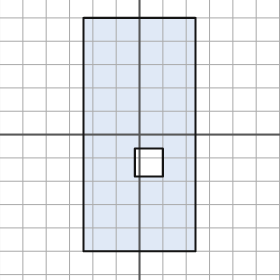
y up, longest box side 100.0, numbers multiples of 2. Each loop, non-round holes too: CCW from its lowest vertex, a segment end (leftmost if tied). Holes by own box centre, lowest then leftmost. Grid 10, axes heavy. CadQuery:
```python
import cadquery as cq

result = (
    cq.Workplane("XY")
    .moveTo(-24.0, -50.0)
    .lineTo(24.0, -50.0)
    .lineTo(24.0, 50.0)
    .lineTo(-24.0, 50.0)
    .close()
    .moveTo(-2.0, -18.0)
    .lineTo(10.0, -18.0)
    .lineTo(10.0, -6.0)
    .lineTo(-2.0, -6.0)
    .close()
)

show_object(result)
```